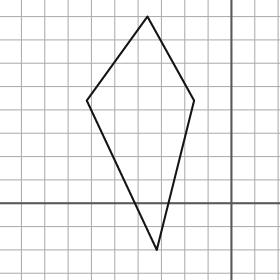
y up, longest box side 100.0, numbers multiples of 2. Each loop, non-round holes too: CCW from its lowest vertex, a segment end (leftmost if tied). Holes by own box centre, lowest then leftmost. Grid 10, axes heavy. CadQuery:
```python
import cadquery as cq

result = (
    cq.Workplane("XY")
    .moveTo(-32.0, -20.0)
    .lineTo(-16.0, 44.0)
    .lineTo(-36.0, 80.0)
    .lineTo(-62.0, 44.0)
    .close()
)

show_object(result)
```